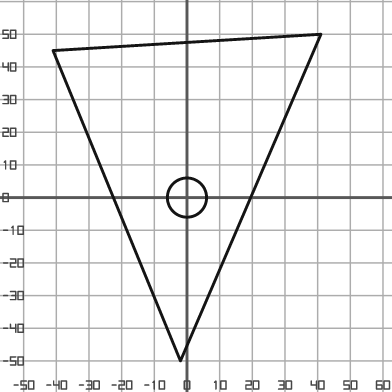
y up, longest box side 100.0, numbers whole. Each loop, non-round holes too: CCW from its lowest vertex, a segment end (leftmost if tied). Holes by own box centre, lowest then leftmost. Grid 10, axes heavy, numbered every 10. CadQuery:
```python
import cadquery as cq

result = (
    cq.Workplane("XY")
    .moveTo(-2.0, -50.0)
    .lineTo(41.0, 50.0)
    .lineTo(-41.0, 45.0)
    .close()
    .moveTo(0.0, 0.0)
    .circle(6.0)
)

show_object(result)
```